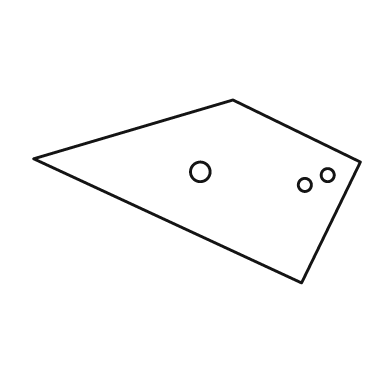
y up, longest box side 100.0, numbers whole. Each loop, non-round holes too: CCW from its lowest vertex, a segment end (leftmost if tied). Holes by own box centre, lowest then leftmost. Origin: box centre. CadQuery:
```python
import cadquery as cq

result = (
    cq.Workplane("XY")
    .moveTo(32.0, -28.0)
    .lineTo(50.0, 9.0)
    .lineTo(11.0, 28.0)
    .lineTo(-50.0, 10.0)
    .close()
    .moveTo(33.0, 2.0)
    .circle(2.0)
    .moveTo(40.0, 5.0)
    .circle(2.0)
    .moveTo(1.0, 6.0)
    .circle(3.0)
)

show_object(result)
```